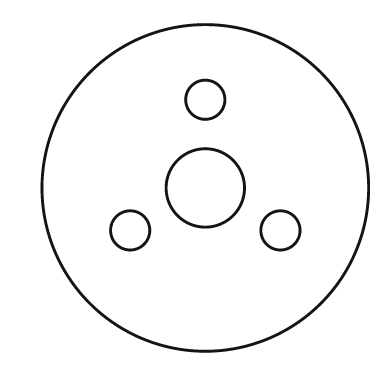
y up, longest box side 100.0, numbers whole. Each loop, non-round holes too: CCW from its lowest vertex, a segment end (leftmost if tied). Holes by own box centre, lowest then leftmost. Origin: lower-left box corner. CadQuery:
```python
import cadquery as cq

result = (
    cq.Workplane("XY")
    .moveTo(50.0, 50.0)
    .circle(50.0)
    .moveTo(27.0, 37.0)
    .circle(6.0)
    .moveTo(73.0, 37.0)
    .circle(6.0)
    .moveTo(50.0, 50.0)
    .circle(12.0)
    .moveTo(50.0, 77.0)
    .circle(6.0)
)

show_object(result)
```